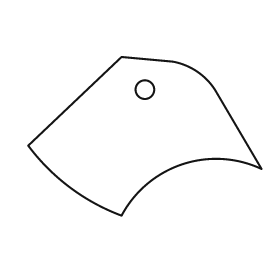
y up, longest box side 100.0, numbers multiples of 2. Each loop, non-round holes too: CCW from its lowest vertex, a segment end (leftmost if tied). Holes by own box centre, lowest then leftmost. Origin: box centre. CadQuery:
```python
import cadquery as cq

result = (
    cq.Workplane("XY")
    .moveTo(-10.0, -34.0)
    .threePointArc((16.0, -12.0), (50.0, -14.0))
    .lineTo(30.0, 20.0)
    .threePointArc((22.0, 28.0), (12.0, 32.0))
    .lineTo(-10.0, 34.0)
    .lineTo(-50.0, -4.0)
    .threePointArc((-32.0, -22.0), (-10.0, -34.0))
    .close()
    .moveTo(0.0, 20.0)
    .circle(4.0)
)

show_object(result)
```